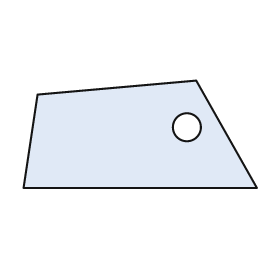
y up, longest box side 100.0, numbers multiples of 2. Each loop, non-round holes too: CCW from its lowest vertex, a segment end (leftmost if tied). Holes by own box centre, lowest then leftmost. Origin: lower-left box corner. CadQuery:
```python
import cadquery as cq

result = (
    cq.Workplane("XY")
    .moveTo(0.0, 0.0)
    .lineTo(100.0, 0.0)
    .lineTo(74.0, 46.0)
    .lineTo(6.0, 40.0)
    .close()
    .moveTo(70.0, 26.0)
    .circle(6.0)
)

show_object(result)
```